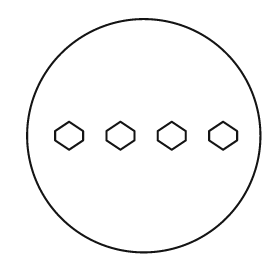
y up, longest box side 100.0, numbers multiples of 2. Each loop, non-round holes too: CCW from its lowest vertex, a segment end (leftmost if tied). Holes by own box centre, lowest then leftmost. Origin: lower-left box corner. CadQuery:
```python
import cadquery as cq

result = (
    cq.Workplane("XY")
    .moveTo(50.0, 50.0)
    .circle(50.0)
    .moveTo(18.0, 44.0)
    .lineTo(24.0, 48.0)
    .lineTo(24.0, 52.0)
    .lineTo(18.0, 56.0)
    .lineTo(12.0, 52.0)
    .lineTo(12.0, 48.0)
    .close()
    .moveTo(40.0, 44.0)
    .lineTo(46.0, 48.0)
    .lineTo(46.0, 52.0)
    .lineTo(40.0, 56.0)
    .lineTo(34.0, 52.0)
    .lineTo(34.0, 48.0)
    .close()
    .moveTo(62.0, 44.0)
    .lineTo(68.0, 48.0)
    .lineTo(68.0, 52.0)
    .lineTo(62.0, 56.0)
    .lineTo(56.0, 52.0)
    .lineTo(56.0, 48.0)
    .close()
    .moveTo(84.0, 44.0)
    .lineTo(90.0, 48.0)
    .lineTo(90.0, 52.0)
    .lineTo(84.0, 56.0)
    .lineTo(78.0, 52.0)
    .lineTo(78.0, 48.0)
    .close()
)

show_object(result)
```